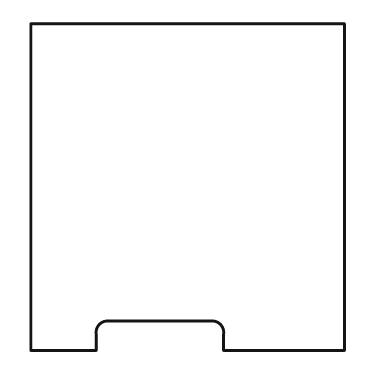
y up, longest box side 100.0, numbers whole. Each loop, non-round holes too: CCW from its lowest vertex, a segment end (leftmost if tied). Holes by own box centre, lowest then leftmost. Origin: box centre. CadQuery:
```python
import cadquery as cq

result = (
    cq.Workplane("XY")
    .moveTo(-48.0, -50.0)
    .lineTo(-28.0, -50.0)
    .lineTo(-28.0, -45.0)
    .threePointArc((-27.0, -42.0), (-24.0, -41.0))
    .lineTo(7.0, -41.0)
    .threePointArc((10.0, -42.0), (11.0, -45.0))
    .lineTo(11.0, -50.0)
    .lineTo(48.0, -50.0)
    .lineTo(48.0, 50.0)
    .lineTo(-48.0, 50.0)
    .close()
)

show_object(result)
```